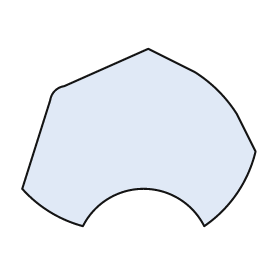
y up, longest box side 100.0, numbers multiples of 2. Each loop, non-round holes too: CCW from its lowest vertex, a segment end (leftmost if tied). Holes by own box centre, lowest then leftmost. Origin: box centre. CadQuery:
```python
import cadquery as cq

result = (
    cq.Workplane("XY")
    .moveTo(-24.0, -38.0)
    .threePointArc((2.0, -22.0), (28.0, -38.0))
    .threePointArc((42.0, -24.0), (50.0, -6.0))
    .lineTo(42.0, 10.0)
    .threePointArc((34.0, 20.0), (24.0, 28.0))
    .lineTo(4.0, 38.0)
    .lineTo(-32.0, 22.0)
    .threePointArc((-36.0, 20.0), (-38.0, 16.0))
    .lineTo(-50.0, -22.0)
    .threePointArc((-38.0, -32.0), (-24.0, -38.0))
    .close()
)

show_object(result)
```